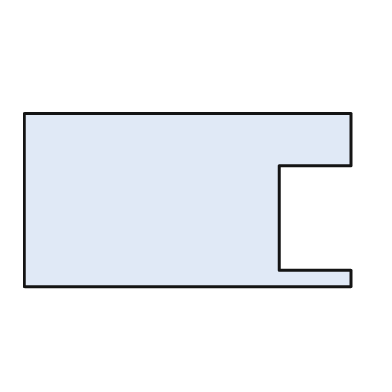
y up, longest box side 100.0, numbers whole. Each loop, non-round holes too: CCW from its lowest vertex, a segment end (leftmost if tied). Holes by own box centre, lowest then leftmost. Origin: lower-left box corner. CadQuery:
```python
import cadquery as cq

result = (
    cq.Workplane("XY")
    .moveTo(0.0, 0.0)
    .lineTo(100.0, 0.0)
    .lineTo(100.0, 5.0)
    .lineTo(78.0, 5.0)
    .lineTo(78.0, 37.0)
    .lineTo(100.0, 37.0)
    .lineTo(100.0, 53.0)
    .lineTo(0.0, 53.0)
    .close()
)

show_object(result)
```